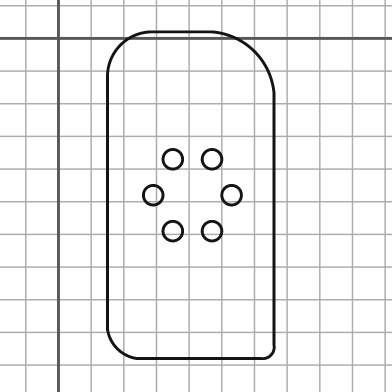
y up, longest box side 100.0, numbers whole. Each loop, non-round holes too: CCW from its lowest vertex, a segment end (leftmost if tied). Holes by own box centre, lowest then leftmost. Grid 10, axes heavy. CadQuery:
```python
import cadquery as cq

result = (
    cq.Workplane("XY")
    .moveTo(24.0, -98.0)
    .lineTo(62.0, -98.0)
    .threePointArc((65.0, -97.0), (66.0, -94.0))
    .lineTo(66.0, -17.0)
    .threePointArc((60.0, -4.0), (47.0, 2.0))
    .lineTo(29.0, 2.0)
    .threePointArc((19.0, -2.0), (15.0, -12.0))
    .lineTo(15.0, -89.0)
    .threePointArc((18.0, -95.0), (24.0, -98.0))
    .close()
    .moveTo(35.0, -59.0)
    .circle(3.0)
    .moveTo(47.0, -59.0)
    .circle(3.0)
    .moveTo(29.0, -48.0)
    .circle(3.0)
    .moveTo(53.0, -48.0)
    .circle(3.0)
    .moveTo(35.0, -37.0)
    .circle(3.0)
    .moveTo(47.0, -37.0)
    .circle(3.0)
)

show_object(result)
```